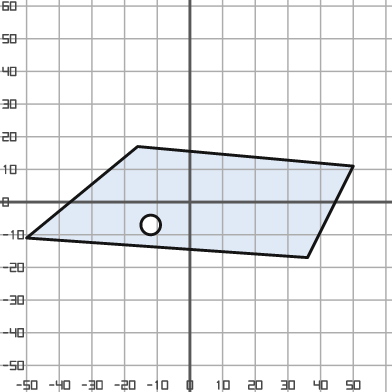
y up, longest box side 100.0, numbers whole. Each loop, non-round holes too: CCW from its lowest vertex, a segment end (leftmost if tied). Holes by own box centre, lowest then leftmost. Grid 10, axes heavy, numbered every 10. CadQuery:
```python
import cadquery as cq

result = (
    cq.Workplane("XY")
    .moveTo(36.0, -17.0)
    .lineTo(50.0, 11.0)
    .lineTo(-16.0, 17.0)
    .lineTo(-50.0, -11.0)
    .close()
    .moveTo(-12.0, -7.0)
    .circle(3.0)
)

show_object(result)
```